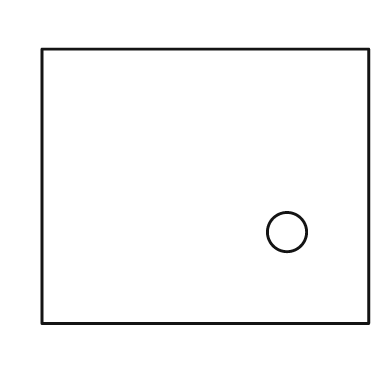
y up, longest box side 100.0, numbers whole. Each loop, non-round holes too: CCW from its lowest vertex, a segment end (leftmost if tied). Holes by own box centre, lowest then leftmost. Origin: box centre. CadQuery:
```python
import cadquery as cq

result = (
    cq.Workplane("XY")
    .moveTo(-50.0, -42.0)
    .lineTo(50.0, -42.0)
    .lineTo(50.0, 42.0)
    .lineTo(-50.0, 42.0)
    .close()
    .moveTo(25.0, -14.0)
    .circle(6.0)
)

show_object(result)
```